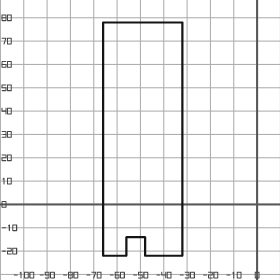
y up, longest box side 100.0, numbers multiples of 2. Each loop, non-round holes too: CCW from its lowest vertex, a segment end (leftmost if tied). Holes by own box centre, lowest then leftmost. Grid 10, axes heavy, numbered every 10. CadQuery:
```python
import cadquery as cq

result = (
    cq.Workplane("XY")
    .moveTo(-66.0, -22.0)
    .lineTo(-56.0, -22.0)
    .lineTo(-56.0, -14.0)
    .lineTo(-48.0, -14.0)
    .lineTo(-48.0, -22.0)
    .lineTo(-32.0, -22.0)
    .lineTo(-32.0, 78.0)
    .lineTo(-66.0, 78.0)
    .close()
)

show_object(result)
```